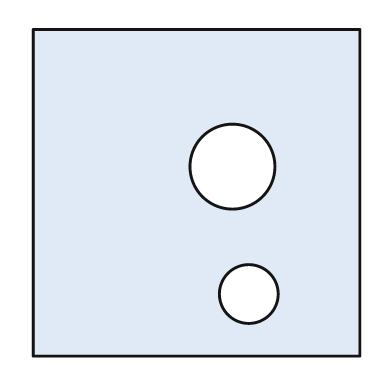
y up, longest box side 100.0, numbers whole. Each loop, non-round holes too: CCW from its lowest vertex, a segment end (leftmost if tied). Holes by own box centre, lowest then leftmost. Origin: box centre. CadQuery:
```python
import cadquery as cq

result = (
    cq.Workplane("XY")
    .moveTo(-50.0, -50.0)
    .lineTo(50.0, -50.0)
    .lineTo(50.0, 50.0)
    .lineTo(-50.0, 50.0)
    .close()
    .moveTo(16.0, -31.0)
    .circle(9.0)
    .moveTo(11.0, 8.0)
    .circle(13.0)
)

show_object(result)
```